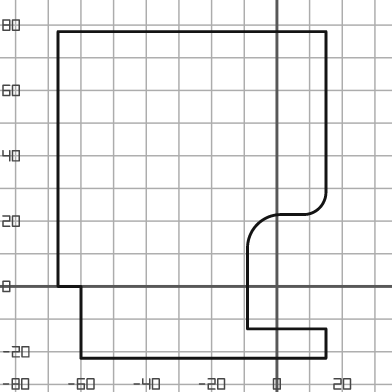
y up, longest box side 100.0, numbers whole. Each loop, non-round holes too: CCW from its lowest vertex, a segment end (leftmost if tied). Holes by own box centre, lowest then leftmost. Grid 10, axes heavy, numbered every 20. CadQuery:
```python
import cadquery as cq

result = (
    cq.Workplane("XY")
    .moveTo(-60.0, -22.0)
    .lineTo(15.0, -22.0)
    .lineTo(15.0, -13.0)
    .lineTo(-9.0, -13.0)
    .lineTo(-9.0, 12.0)
    .threePointArc((-6.0, 19.0), (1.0, 22.0))
    .lineTo(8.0, 22.0)
    .threePointArc((13.0, 24.0), (15.0, 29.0))
    .lineTo(15.0, 78.0)
    .lineTo(-67.0, 78.0)
    .lineTo(-67.0, 0.0)
    .lineTo(-60.0, 0.0)
    .close()
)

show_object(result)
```